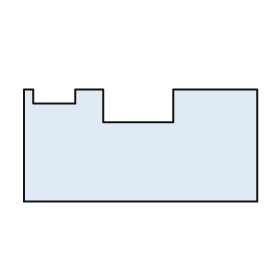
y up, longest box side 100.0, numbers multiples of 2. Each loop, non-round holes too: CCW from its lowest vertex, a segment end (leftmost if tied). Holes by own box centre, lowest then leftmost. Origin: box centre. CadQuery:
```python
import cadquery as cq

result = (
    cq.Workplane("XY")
    .moveTo(-50.0, -24.0)
    .lineTo(50.0, -24.0)
    .lineTo(50.0, 24.0)
    .lineTo(14.0, 24.0)
    .lineTo(14.0, 10.0)
    .lineTo(-16.0, 10.0)
    .lineTo(-16.0, 24.0)
    .lineTo(-28.0, 24.0)
    .lineTo(-28.0, 18.0)
    .lineTo(-46.0, 18.0)
    .lineTo(-46.0, 24.0)
    .lineTo(-50.0, 24.0)
    .close()
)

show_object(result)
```